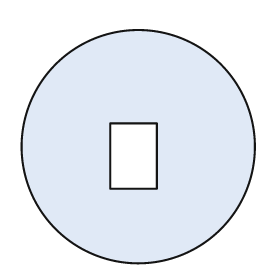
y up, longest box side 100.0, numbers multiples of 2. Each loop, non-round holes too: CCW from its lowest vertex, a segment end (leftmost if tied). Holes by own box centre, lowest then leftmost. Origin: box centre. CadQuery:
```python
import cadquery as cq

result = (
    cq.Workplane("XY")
    .moveTo(0.0, 0.0)
    .circle(50.0)
    .moveTo(-12.0, -18.0)
    .lineTo(8.0, -18.0)
    .lineTo(8.0, 10.0)
    .lineTo(-12.0, 10.0)
    .close()
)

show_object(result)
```